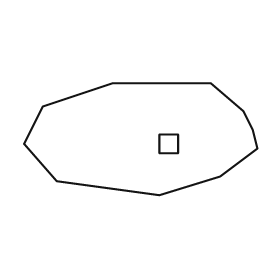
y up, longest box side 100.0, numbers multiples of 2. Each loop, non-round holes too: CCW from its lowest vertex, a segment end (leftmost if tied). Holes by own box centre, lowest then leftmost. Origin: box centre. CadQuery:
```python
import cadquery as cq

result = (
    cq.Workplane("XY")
    .moveTo(8.0, -24.0)
    .lineTo(34.0, -16.0)
    .lineTo(50.0, -4.0)
    .lineTo(48.0, 4.0)
    .lineTo(44.0, 12.0)
    .lineTo(30.0, 24.0)
    .lineTo(-12.0, 24.0)
    .lineTo(-42.0, 14.0)
    .lineTo(-50.0, -2.0)
    .lineTo(-36.0, -18.0)
    .close()
    .moveTo(8.0, -6.0)
    .lineTo(16.0, -6.0)
    .lineTo(16.0, 2.0)
    .lineTo(8.0, 2.0)
    .close()
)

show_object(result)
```